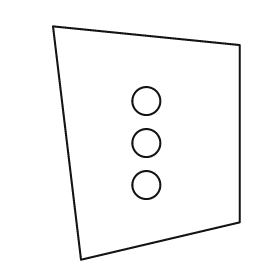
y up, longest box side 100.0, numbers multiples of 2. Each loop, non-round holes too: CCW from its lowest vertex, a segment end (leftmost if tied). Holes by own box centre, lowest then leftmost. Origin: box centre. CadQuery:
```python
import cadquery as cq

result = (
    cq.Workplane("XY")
    .moveTo(-28.0, -50.0)
    .lineTo(40.0, -34.0)
    .lineTo(40.0, 42.0)
    .lineTo(-40.0, 50.0)
    .close()
    .moveTo(0.0, -18.0)
    .circle(6.0)
    .moveTo(0.0, 0.0)
    .circle(6.0)
    .moveTo(0.0, 18.0)
    .circle(6.0)
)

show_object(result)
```